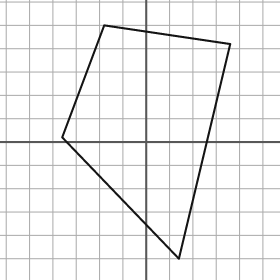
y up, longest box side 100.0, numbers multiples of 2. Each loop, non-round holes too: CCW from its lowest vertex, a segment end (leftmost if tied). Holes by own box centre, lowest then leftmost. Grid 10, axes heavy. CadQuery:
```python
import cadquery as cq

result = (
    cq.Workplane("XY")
    .moveTo(14.0, -50.0)
    .lineTo(36.0, 42.0)
    .lineTo(-18.0, 50.0)
    .lineTo(-36.0, 2.0)
    .close()
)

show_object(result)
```